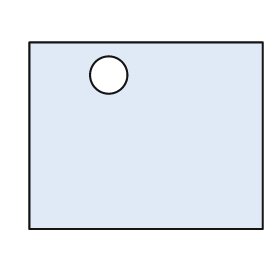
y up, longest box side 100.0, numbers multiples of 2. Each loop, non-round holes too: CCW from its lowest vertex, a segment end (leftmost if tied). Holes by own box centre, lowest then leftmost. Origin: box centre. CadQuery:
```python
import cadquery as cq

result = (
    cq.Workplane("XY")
    .moveTo(-50.0, -40.0)
    .lineTo(50.0, -40.0)
    .lineTo(50.0, 40.0)
    .lineTo(-50.0, 40.0)
    .close()
    .moveTo(-16.0, 26.0)
    .circle(8.0)
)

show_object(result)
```